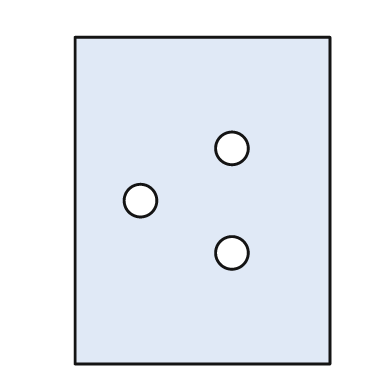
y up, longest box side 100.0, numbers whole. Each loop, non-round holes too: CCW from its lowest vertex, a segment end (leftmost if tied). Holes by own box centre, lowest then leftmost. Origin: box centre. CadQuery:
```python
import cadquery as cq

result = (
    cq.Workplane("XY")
    .moveTo(-39.0, -50.0)
    .lineTo(39.0, -50.0)
    .lineTo(39.0, 50.0)
    .lineTo(-39.0, 50.0)
    .close()
    .moveTo(9.0, -16.0)
    .circle(5.0)
    .moveTo(-19.0, 0.0)
    .circle(5.0)
    .moveTo(9.0, 16.0)
    .circle(5.0)
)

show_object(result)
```